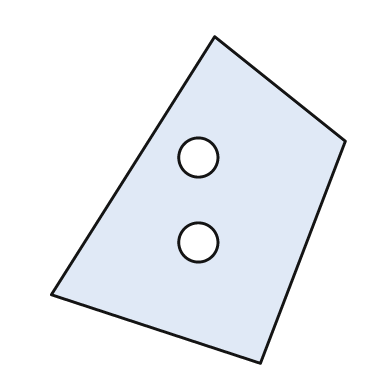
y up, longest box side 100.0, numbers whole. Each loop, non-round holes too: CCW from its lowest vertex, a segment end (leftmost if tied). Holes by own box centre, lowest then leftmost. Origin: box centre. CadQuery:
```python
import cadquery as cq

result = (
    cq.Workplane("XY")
    .moveTo(19.0, -50.0)
    .lineTo(45.0, 18.0)
    .lineTo(5.0, 50.0)
    .lineTo(-45.0, -29.0)
    .close()
    .moveTo(0.0, -13.0)
    .circle(6.0)
    .moveTo(0.0, 13.0)
    .circle(6.0)
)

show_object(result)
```